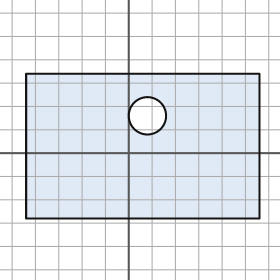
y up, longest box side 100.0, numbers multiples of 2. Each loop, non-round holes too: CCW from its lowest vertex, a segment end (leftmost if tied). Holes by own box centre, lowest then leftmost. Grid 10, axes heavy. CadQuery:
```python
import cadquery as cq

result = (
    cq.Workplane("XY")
    .moveTo(-44.0, -28.0)
    .lineTo(56.0, -28.0)
    .lineTo(56.0, 34.0)
    .lineTo(-44.0, 34.0)
    .close()
    .moveTo(8.0, 16.0)
    .circle(8.0)
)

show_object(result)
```